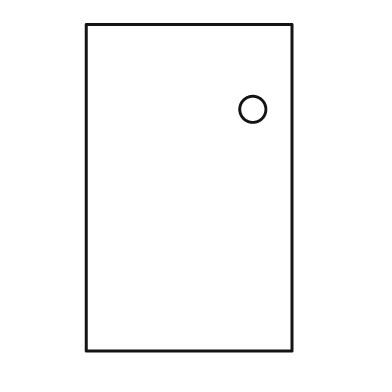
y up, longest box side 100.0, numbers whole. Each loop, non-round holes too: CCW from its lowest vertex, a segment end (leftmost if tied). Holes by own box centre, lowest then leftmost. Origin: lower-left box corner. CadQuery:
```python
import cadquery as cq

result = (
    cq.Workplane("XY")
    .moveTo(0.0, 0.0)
    .lineTo(63.0, 0.0)
    .lineTo(63.0, 100.0)
    .lineTo(0.0, 100.0)
    .close()
    .moveTo(51.0, 74.0)
    .circle(4.0)
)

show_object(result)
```